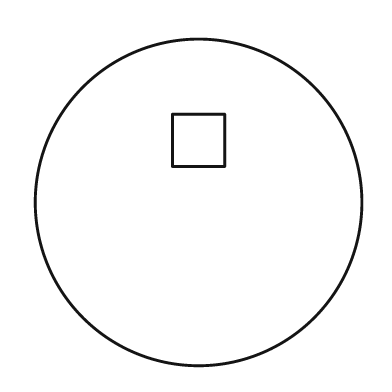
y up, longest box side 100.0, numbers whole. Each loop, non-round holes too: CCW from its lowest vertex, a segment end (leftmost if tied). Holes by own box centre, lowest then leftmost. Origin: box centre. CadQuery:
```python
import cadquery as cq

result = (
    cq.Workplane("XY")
    .moveTo(0.0, 0.0)
    .circle(50.0)
    .moveTo(-8.0, 11.0)
    .lineTo(8.0, 11.0)
    .lineTo(8.0, 27.0)
    .lineTo(-8.0, 27.0)
    .close()
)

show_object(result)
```